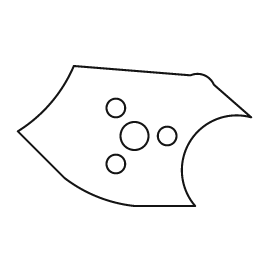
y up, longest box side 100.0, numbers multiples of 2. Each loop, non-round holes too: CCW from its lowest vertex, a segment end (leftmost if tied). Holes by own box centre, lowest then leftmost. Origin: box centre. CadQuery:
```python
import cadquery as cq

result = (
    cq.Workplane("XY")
    .moveTo(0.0, -30.0)
    .lineTo(26.0, -30.0)
    .threePointArc((24.0, -2.0), (50.0, 8.0))
    .lineTo(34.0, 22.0)
    .threePointArc((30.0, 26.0), (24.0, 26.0))
    .lineTo(-26.0, 30.0)
    .threePointArc((-36.0, 14.0), (-50.0, 2.0))
    .lineTo(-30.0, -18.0)
    .threePointArc((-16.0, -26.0), (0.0, -30.0))
    .close()
    .moveTo(-8.0, -12.0)
    .circle(4.0)
    .moveTo(0.0, 0.0)
    .circle(6.0)
    .moveTo(14.0, 0.0)
    .circle(4.0)
    .moveTo(-8.0, 12.0)
    .circle(4.0)
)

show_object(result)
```